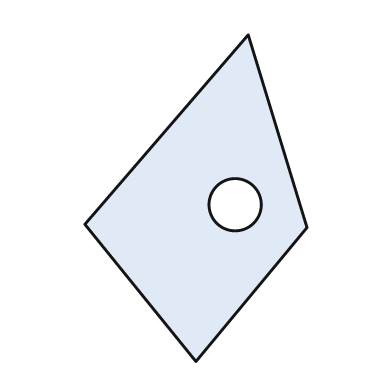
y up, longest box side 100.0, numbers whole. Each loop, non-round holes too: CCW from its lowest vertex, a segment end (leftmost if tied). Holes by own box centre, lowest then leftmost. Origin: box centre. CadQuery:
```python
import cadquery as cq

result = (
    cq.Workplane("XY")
    .moveTo(0.0, -50.0)
    .lineTo(34.0, -9.0)
    .lineTo(16.0, 50.0)
    .lineTo(-34.0, -8.0)
    .close()
    .moveTo(12.0, -2.0)
    .circle(8.0)
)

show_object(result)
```